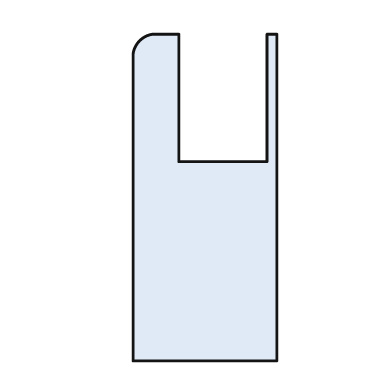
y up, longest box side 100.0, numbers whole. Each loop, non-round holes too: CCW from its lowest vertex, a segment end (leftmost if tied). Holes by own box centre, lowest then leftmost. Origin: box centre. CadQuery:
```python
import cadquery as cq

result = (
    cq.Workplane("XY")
    .moveTo(-22.0, -50.0)
    .lineTo(22.0, -50.0)
    .lineTo(22.0, 50.0)
    .lineTo(19.0, 50.0)
    .lineTo(19.0, 11.0)
    .lineTo(-8.0, 11.0)
    .lineTo(-8.0, 50.0)
    .lineTo(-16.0, 50.0)
    .threePointArc((-20.0, 48.0), (-22.0, 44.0))
    .close()
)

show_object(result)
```